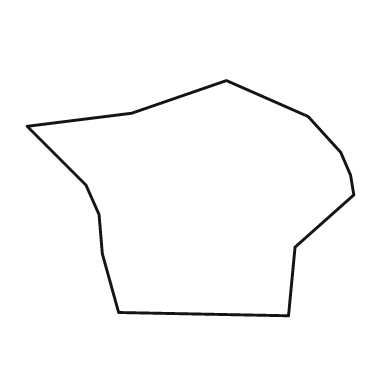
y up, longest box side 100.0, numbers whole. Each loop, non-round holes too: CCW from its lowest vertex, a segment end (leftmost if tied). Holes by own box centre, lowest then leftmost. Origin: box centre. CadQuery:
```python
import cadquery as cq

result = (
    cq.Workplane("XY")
    .moveTo(30.0, -36.0)
    .lineTo(32.0, -15.0)
    .lineTo(50.0, 1.0)
    .lineTo(49.0, 7.0)
    .lineTo(46.0, 14.0)
    .lineTo(36.0, 25.0)
    .lineTo(11.0, 36.0)
    .lineTo(-18.0, 26.0)
    .lineTo(-50.0, 22.0)
    .lineTo(-32.0, 4.0)
    .lineTo(-28.0, -5.0)
    .lineTo(-27.0, -17.0)
    .lineTo(-22.0, -35.0)
    .close()
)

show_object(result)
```